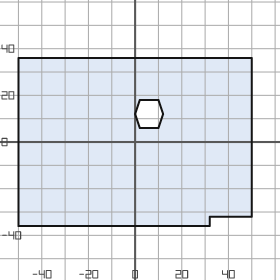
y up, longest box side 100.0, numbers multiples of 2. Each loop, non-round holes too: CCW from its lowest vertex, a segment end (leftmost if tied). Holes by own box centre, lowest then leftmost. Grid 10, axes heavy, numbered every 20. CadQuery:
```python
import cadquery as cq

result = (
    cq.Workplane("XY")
    .moveTo(-50.0, -36.0)
    .lineTo(32.0, -36.0)
    .lineTo(32.0, -32.0)
    .lineTo(50.0, -32.0)
    .lineTo(50.0, 36.0)
    .lineTo(-50.0, 36.0)
    .close()
    .moveTo(2.0, 6.0)
    .lineTo(10.0, 6.0)
    .lineTo(12.0, 12.0)
    .lineTo(10.0, 18.0)
    .lineTo(2.0, 18.0)
    .lineTo(0.0, 12.0)
    .close()
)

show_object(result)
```